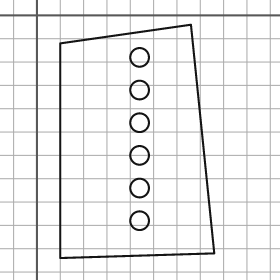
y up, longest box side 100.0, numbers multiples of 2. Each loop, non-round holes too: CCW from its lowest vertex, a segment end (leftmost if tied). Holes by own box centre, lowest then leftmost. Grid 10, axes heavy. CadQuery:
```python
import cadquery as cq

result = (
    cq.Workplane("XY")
    .moveTo(10.0, -104.0)
    .lineTo(76.0, -102.0)
    .lineTo(66.0, -4.0)
    .lineTo(10.0, -12.0)
    .close()
    .moveTo(44.0, -88.0)
    .circle(4.0)
    .moveTo(44.0, -74.0)
    .circle(4.0)
    .moveTo(44.0, -60.0)
    .circle(4.0)
    .moveTo(44.0, -46.0)
    .circle(4.0)
    .moveTo(44.0, -32.0)
    .circle(4.0)
    .moveTo(44.0, -18.0)
    .circle(4.0)
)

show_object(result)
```